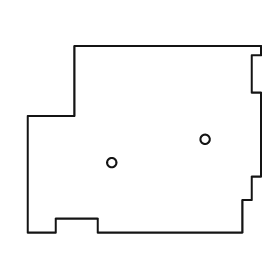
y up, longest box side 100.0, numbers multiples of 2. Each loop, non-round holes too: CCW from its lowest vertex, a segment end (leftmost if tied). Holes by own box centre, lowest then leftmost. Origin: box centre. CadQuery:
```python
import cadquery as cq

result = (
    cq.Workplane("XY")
    .moveTo(-50.0, -40.0)
    .lineTo(-38.0, -40.0)
    .lineTo(-38.0, -34.0)
    .lineTo(-20.0, -34.0)
    .lineTo(-20.0, -40.0)
    .lineTo(42.0, -40.0)
    .lineTo(42.0, -26.0)
    .lineTo(46.0, -26.0)
    .lineTo(46.0, -16.0)
    .lineTo(50.0, -16.0)
    .lineTo(50.0, 20.0)
    .lineTo(46.0, 20.0)
    .lineTo(46.0, 36.0)
    .lineTo(50.0, 36.0)
    .lineTo(50.0, 40.0)
    .lineTo(-30.0, 40.0)
    .lineTo(-30.0, 10.0)
    .lineTo(-50.0, 10.0)
    .close()
    .moveTo(-14.0, -10.0)
    .circle(2.0)
    .moveTo(26.0, 0.0)
    .circle(2.0)
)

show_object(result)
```